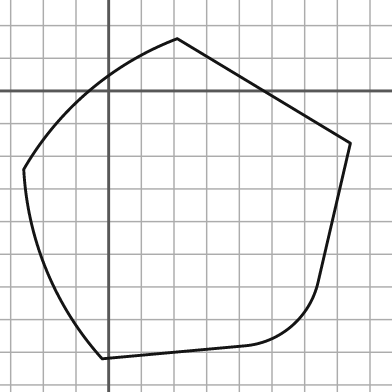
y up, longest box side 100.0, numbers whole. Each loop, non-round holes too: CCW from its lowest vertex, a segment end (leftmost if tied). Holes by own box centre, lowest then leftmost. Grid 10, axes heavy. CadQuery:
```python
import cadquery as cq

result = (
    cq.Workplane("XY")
    .moveTo(-2.0, -82.0)
    .lineTo(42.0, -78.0)
    .threePointArc((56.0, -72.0), (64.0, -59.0))
    .lineTo(74.0, -16.0)
    .lineTo(21.0, 16.0)
    .threePointArc((-6.0, 0.0), (-26.0, -24.0))
    .threePointArc((-19.0, -55.0), (-2.0, -82.0))
    .close()
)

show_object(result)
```